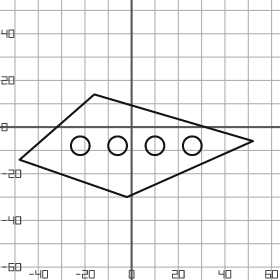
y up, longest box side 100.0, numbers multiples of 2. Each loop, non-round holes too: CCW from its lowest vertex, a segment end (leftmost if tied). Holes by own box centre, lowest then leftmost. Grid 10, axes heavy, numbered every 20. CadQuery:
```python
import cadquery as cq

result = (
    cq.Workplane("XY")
    .moveTo(-2.0, -30.0)
    .lineTo(52.0, -6.0)
    .lineTo(-16.0, 14.0)
    .lineTo(-48.0, -14.0)
    .close()
    .moveTo(-22.0, -8.0)
    .circle(4.0)
    .moveTo(-6.0, -8.0)
    .circle(4.0)
    .moveTo(10.0, -8.0)
    .circle(4.0)
    .moveTo(26.0, -8.0)
    .circle(4.0)
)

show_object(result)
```